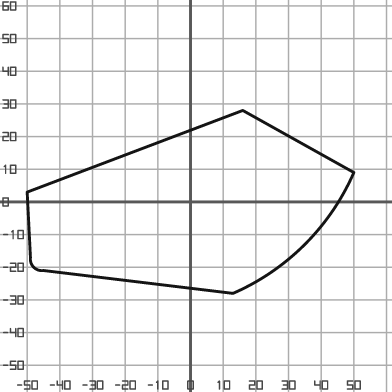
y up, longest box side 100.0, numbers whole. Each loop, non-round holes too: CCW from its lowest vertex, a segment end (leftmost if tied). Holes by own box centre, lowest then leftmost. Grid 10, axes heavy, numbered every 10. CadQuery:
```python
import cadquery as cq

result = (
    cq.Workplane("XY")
    .moveTo(13.0, -28.0)
    .threePointArc((35.0, -13.0), (50.0, 9.0))
    .lineTo(16.0, 28.0)
    .lineTo(-50.0, 3.0)
    .lineTo(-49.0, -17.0)
    .threePointArc((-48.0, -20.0), (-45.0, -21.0))
    .close()
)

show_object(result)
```